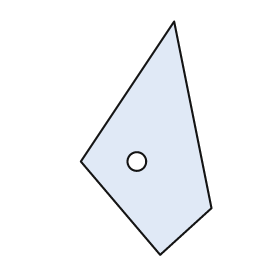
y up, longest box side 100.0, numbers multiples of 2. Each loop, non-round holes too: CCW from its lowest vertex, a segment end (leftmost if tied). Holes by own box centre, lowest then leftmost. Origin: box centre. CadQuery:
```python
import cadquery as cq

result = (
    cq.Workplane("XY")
    .moveTo(6.0, -50.0)
    .lineTo(28.0, -30.0)
    .lineTo(12.0, 50.0)
    .lineTo(-28.0, -10.0)
    .close()
    .moveTo(-4.0, -10.0)
    .circle(4.0)
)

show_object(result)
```